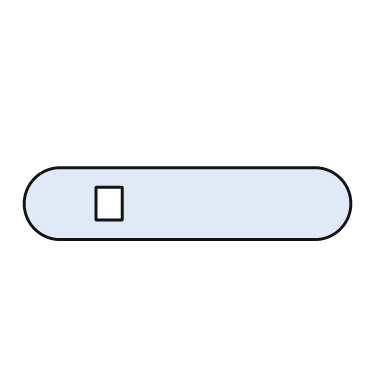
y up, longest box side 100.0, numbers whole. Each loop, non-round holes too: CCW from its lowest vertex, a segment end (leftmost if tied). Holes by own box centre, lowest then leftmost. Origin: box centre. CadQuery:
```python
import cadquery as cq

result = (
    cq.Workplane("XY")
    .moveTo(-39.0, -11.0)
    .lineTo(39.0, -11.0)
    .threePointArc((50.0, 0.0), (39.0, 11.0))
    .lineTo(-39.0, 11.0)
    .threePointArc((-50.0, 0.0), (-39.0, -11.0))
    .close()
    .moveTo(-28.0, -5.0)
    .lineTo(-20.0, -5.0)
    .lineTo(-20.0, 5.0)
    .lineTo(-28.0, 5.0)
    .close()
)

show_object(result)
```